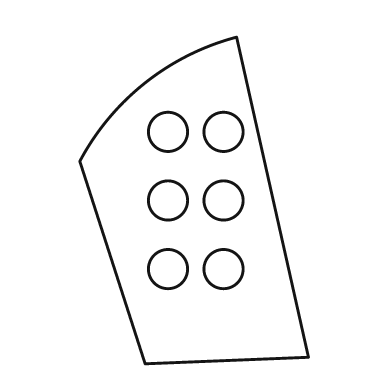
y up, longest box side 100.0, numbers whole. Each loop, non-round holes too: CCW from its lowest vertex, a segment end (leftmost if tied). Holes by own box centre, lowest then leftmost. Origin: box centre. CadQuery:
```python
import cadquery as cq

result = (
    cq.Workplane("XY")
    .moveTo(-15.0, -50.0)
    .lineTo(35.0, -48.0)
    .lineTo(13.0, 50.0)
    .threePointArc((-15.0, 36.0), (-35.0, 12.0))
    .close()
    .moveTo(-8.0, -21.0)
    .circle(6.0)
    .moveTo(9.0, -21.0)
    .circle(6.0)
    .moveTo(-8.0, 0.0)
    .circle(6.0)
    .moveTo(9.0, 0.0)
    .circle(6.0)
    .moveTo(-8.0, 21.0)
    .circle(6.0)
    .moveTo(9.0, 21.0)
    .circle(6.0)
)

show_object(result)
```